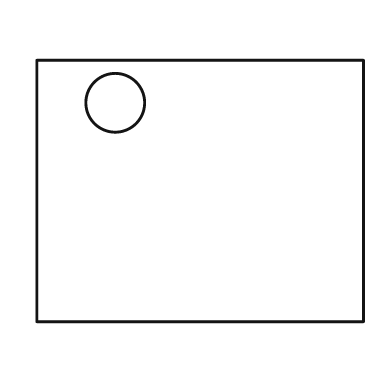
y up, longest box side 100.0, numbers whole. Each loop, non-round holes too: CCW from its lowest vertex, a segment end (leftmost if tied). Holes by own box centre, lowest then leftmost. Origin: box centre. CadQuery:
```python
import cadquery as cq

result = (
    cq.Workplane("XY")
    .moveTo(-50.0, -40.0)
    .lineTo(50.0, -40.0)
    .lineTo(50.0, 40.0)
    .lineTo(-50.0, 40.0)
    .close()
    .moveTo(-26.0, 27.0)
    .circle(9.0)
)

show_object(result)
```